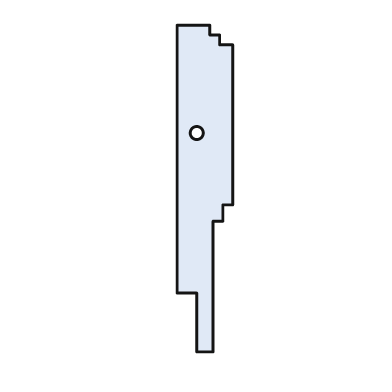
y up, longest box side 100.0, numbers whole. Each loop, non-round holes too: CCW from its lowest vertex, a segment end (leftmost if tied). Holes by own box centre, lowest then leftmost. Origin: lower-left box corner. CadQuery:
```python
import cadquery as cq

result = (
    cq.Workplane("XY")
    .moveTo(6.0, 0.0)
    .lineTo(11.0, 0.0)
    .lineTo(11.0, 40.0)
    .lineTo(14.0, 40.0)
    .lineTo(14.0, 45.0)
    .lineTo(17.0, 45.0)
    .lineTo(17.0, 94.0)
    .lineTo(13.0, 94.0)
    .lineTo(13.0, 97.0)
    .lineTo(10.0, 97.0)
    .lineTo(10.0, 100.0)
    .lineTo(0.0, 100.0)
    .lineTo(0.0, 18.0)
    .lineTo(6.0, 18.0)
    .close()
    .moveTo(6.0, 67.0)
    .circle(2.0)
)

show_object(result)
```